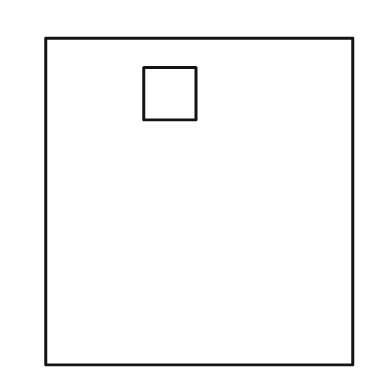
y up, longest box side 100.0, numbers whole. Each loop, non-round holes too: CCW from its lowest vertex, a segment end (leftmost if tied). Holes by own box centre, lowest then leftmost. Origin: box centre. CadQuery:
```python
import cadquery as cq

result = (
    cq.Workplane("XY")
    .moveTo(-47.0, -50.0)
    .lineTo(47.0, -50.0)
    .lineTo(47.0, 50.0)
    .lineTo(-47.0, 50.0)
    .close()
    .moveTo(-17.0, 25.0)
    .lineTo(-1.0, 25.0)
    .lineTo(-1.0, 41.0)
    .lineTo(-17.0, 41.0)
    .close()
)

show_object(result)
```